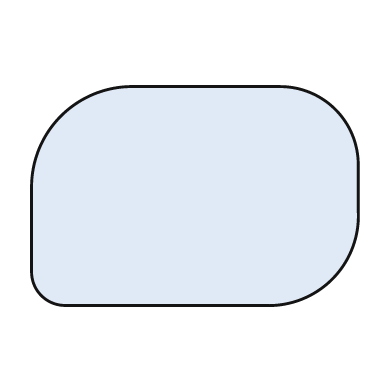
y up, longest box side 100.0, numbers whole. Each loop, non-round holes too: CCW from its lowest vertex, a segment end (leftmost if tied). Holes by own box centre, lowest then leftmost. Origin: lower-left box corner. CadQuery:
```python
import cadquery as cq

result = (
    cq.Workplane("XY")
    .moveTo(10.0, 0.0)
    .lineTo(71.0, 0.0)
    .threePointArc((92.0, 8.0), (100.0, 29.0))
    .lineTo(100.0, 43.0)
    .threePointArc((93.0, 60.0), (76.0, 67.0))
    .lineTo(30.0, 67.0)
    .threePointArc((9.0, 58.0), (0.0, 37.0))
    .lineTo(0.0, 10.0)
    .threePointArc((3.0, 3.0), (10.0, 0.0))
    .close()
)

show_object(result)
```